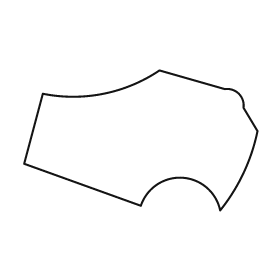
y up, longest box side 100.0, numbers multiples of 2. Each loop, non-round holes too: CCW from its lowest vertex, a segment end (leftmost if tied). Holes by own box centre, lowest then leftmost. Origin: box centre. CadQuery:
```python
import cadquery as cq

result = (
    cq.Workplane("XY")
    .moveTo(34.0, -30.0)
    .threePointArc((44.0, -14.0), (50.0, 4.0))
    .lineTo(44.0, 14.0)
    .threePointArc((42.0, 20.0), (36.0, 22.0))
    .lineTo(8.0, 30.0)
    .threePointArc((-16.0, 20.0), (-42.0, 20.0))
    .lineTo(-50.0, -10.0)
    .lineTo(0.0, -28.0)
    .threePointArc((18.0, -16.0), (34.0, -30.0))
    .close()
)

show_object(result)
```